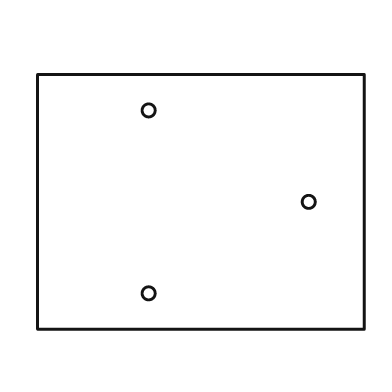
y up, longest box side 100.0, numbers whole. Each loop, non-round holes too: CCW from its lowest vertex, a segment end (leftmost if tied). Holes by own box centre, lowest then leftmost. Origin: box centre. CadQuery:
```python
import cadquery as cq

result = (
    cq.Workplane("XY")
    .moveTo(-50.0, -39.0)
    .lineTo(50.0, -39.0)
    .lineTo(50.0, 39.0)
    .lineTo(-50.0, 39.0)
    .close()
    .moveTo(-16.0, -28.0)
    .circle(2.0)
    .moveTo(33.0, 0.0)
    .circle(2.0)
    .moveTo(-16.0, 28.0)
    .circle(2.0)
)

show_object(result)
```